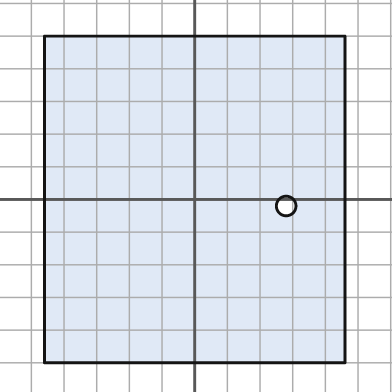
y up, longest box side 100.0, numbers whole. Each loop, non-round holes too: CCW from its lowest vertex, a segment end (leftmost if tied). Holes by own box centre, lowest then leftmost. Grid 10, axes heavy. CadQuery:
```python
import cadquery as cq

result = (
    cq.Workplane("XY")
    .moveTo(-46.0, -50.0)
    .lineTo(46.0, -50.0)
    .lineTo(46.0, 50.0)
    .lineTo(-46.0, 50.0)
    .close()
    .moveTo(28.0, -2.0)
    .circle(3.0)
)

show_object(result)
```